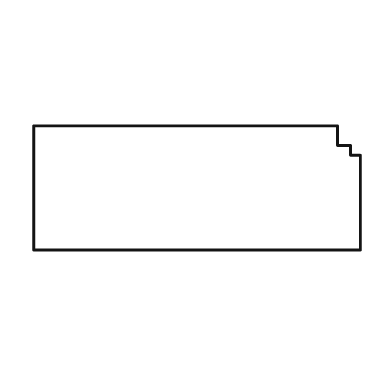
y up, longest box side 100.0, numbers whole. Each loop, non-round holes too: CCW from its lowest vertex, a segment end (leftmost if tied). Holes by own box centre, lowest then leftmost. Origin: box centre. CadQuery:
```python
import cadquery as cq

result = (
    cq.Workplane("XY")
    .moveTo(-50.0, -19.0)
    .lineTo(50.0, -19.0)
    .lineTo(50.0, 10.0)
    .lineTo(47.0, 10.0)
    .lineTo(47.0, 13.0)
    .lineTo(43.0, 13.0)
    .lineTo(43.0, 19.0)
    .lineTo(-50.0, 19.0)
    .close()
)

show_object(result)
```